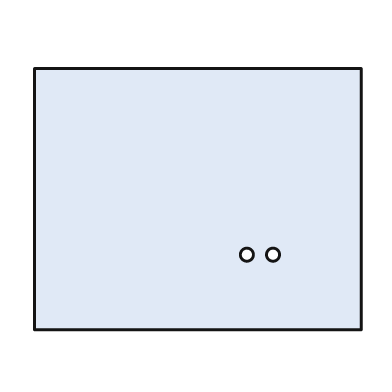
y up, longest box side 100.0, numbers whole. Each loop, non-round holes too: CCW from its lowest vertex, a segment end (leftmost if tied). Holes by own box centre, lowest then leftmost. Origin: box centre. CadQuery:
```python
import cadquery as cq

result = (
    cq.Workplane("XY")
    .moveTo(-50.0, -40.0)
    .lineTo(50.0, -40.0)
    .lineTo(50.0, 40.0)
    .lineTo(-50.0, 40.0)
    .close()
    .moveTo(15.0, -17.0)
    .circle(2.0)
    .moveTo(23.0, -17.0)
    .circle(2.0)
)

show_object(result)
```